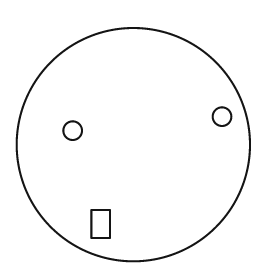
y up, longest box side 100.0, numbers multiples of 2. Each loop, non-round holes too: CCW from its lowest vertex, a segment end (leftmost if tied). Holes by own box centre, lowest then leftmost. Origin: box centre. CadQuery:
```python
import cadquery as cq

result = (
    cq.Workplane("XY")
    .moveTo(0.0, 0.0)
    .circle(50.0)
    .moveTo(-18.0, -40.0)
    .lineTo(-10.0, -40.0)
    .lineTo(-10.0, -28.0)
    .lineTo(-18.0, -28.0)
    .close()
    .moveTo(-26.0, 6.0)
    .circle(4.0)
    .moveTo(38.0, 12.0)
    .circle(4.0)
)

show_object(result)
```